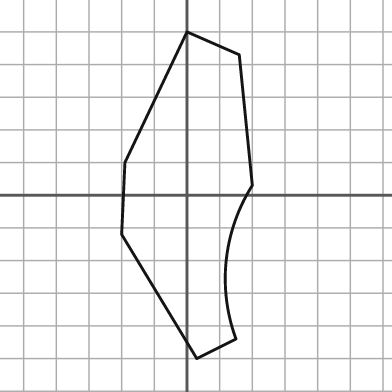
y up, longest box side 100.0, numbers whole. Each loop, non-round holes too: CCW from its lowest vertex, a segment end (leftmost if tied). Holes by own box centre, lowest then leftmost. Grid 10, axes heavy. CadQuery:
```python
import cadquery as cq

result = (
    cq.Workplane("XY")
    .moveTo(3.0, -50.0)
    .lineTo(15.0, -44.0)
    .threePointArc((12.0, -20.0), (20.0, 3.0))
    .lineTo(16.0, 43.0)
    .lineTo(0.0, 50.0)
    .lineTo(-19.0, 10.0)
    .lineTo(-20.0, -12.0)
    .close()
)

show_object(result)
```